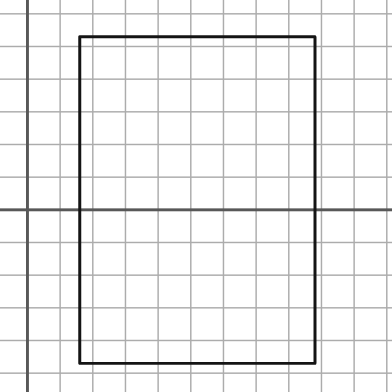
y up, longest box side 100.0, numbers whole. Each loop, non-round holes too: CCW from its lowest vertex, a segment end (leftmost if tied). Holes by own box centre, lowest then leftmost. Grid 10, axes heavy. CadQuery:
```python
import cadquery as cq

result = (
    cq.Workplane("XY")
    .moveTo(16.0, -47.0)
    .lineTo(88.0, -47.0)
    .lineTo(88.0, 53.0)
    .lineTo(16.0, 53.0)
    .close()
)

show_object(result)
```